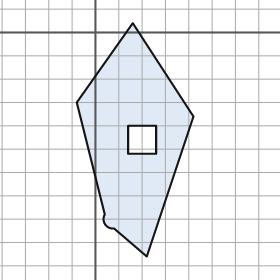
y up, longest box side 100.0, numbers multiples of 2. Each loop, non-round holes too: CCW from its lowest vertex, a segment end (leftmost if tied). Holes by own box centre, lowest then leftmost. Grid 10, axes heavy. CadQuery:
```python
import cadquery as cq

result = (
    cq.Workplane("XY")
    .moveTo(22.0, -96.0)
    .lineTo(42.0, -36.0)
    .lineTo(16.0, 4.0)
    .lineTo(-8.0, -30.0)
    .lineTo(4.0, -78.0)
    .threePointArc((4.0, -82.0), (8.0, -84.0))
    .close()
    .moveTo(14.0, -52.0)
    .lineTo(26.0, -52.0)
    .lineTo(26.0, -40.0)
    .lineTo(14.0, -40.0)
    .close()
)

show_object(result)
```